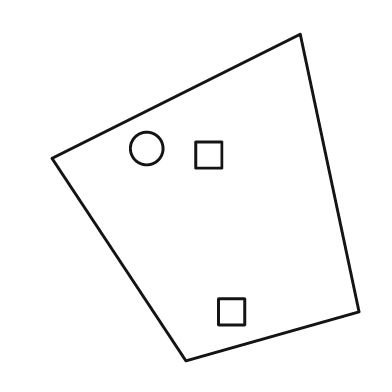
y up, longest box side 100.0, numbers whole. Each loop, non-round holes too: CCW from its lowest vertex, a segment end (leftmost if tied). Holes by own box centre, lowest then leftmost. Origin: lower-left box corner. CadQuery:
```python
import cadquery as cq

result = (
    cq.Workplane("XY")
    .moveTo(41.0, 0.0)
    .lineTo(94.0, 15.0)
    .lineTo(76.0, 100.0)
    .lineTo(0.0, 62.0)
    .close()
    .moveTo(51.0, 11.0)
    .lineTo(59.0, 11.0)
    .lineTo(59.0, 19.0)
    .lineTo(51.0, 19.0)
    .close()
    .moveTo(44.0, 59.0)
    .lineTo(52.0, 59.0)
    .lineTo(52.0, 67.0)
    .lineTo(44.0, 67.0)
    .close()
    .moveTo(29.0, 65.0)
    .circle(5.0)
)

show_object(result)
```